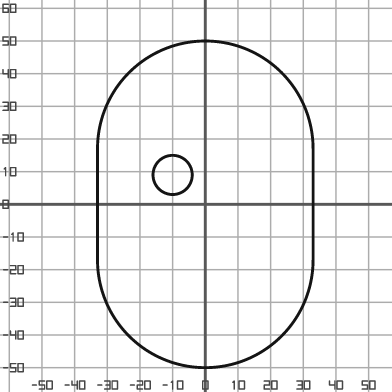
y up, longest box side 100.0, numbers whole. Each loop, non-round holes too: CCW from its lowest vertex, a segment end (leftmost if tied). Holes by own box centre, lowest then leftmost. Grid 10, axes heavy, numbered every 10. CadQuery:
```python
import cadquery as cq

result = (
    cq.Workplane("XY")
    .moveTo(-33.0, -17.0)
    .threePointArc((0.0, -50.0), (33.0, -17.0))
    .lineTo(33.0, 17.0)
    .threePointArc((0.0, 50.0), (-33.0, 17.0))
    .close()
    .moveTo(-10.0, 9.0)
    .circle(6.0)
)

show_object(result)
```